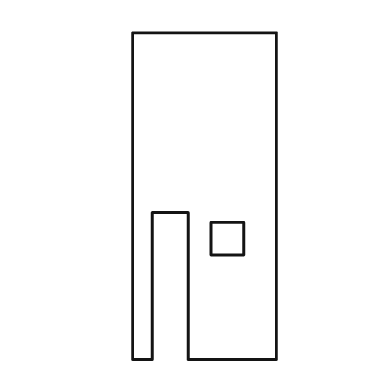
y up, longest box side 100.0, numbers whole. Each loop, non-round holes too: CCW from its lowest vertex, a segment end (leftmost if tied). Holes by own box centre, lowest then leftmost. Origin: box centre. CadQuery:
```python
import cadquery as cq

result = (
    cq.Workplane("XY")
    .moveTo(-22.0, -50.0)
    .lineTo(-16.0, -50.0)
    .lineTo(-16.0, -5.0)
    .lineTo(-5.0, -5.0)
    .lineTo(-5.0, -50.0)
    .lineTo(22.0, -50.0)
    .lineTo(22.0, 50.0)
    .lineTo(-22.0, 50.0)
    .close()
    .moveTo(2.0, -18.0)
    .lineTo(12.0, -18.0)
    .lineTo(12.0, -8.0)
    .lineTo(2.0, -8.0)
    .close()
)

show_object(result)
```